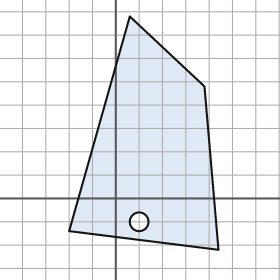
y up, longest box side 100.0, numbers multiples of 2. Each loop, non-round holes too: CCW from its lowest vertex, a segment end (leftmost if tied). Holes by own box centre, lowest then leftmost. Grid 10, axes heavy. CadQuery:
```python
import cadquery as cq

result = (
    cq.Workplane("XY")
    .moveTo(44.0, -22.0)
    .lineTo(38.0, 48.0)
    .lineTo(6.0, 78.0)
    .lineTo(-20.0, -14.0)
    .close()
    .moveTo(10.0, -10.0)
    .circle(4.0)
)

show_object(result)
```